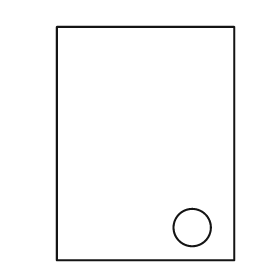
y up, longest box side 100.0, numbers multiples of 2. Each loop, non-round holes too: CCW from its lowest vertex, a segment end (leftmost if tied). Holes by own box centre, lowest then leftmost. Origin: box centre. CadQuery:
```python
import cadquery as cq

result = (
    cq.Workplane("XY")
    .moveTo(-38.0, -50.0)
    .lineTo(38.0, -50.0)
    .lineTo(38.0, 50.0)
    .lineTo(-38.0, 50.0)
    .close()
    .moveTo(20.0, -36.0)
    .circle(8.0)
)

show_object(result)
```